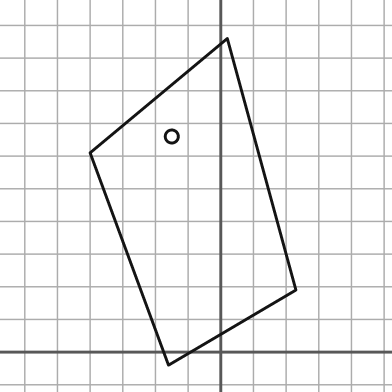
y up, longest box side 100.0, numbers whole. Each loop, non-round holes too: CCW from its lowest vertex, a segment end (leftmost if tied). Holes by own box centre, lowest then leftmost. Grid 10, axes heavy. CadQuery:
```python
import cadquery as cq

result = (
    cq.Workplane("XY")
    .moveTo(-16.0, -4.0)
    .lineTo(23.0, 19.0)
    .lineTo(2.0, 96.0)
    .lineTo(-40.0, 61.0)
    .close()
    .moveTo(-15.0, 66.0)
    .circle(2.0)
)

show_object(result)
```